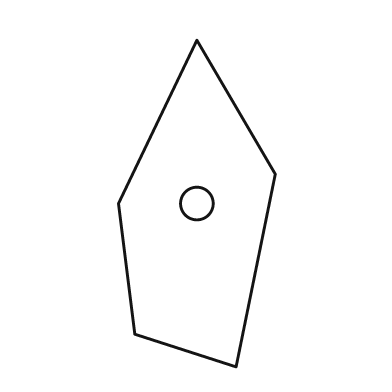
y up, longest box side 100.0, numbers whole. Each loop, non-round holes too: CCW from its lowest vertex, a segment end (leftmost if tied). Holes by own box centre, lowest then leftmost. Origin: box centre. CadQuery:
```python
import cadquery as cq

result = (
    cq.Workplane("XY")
    .moveTo(12.0, -50.0)
    .lineTo(24.0, 9.0)
    .lineTo(0.0, 50.0)
    .lineTo(-24.0, 0.0)
    .lineTo(-19.0, -40.0)
    .close()
    .moveTo(0.0, 0.0)
    .circle(5.0)
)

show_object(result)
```